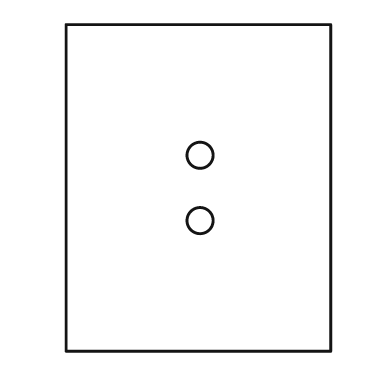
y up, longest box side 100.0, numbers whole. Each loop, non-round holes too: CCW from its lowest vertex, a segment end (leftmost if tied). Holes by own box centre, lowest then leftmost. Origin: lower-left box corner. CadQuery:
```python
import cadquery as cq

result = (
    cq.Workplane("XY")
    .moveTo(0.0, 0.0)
    .lineTo(81.0, 0.0)
    .lineTo(81.0, 100.0)
    .lineTo(0.0, 100.0)
    .close()
    .moveTo(41.0, 40.0)
    .circle(4.0)
    .moveTo(41.0, 60.0)
    .circle(4.0)
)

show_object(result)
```